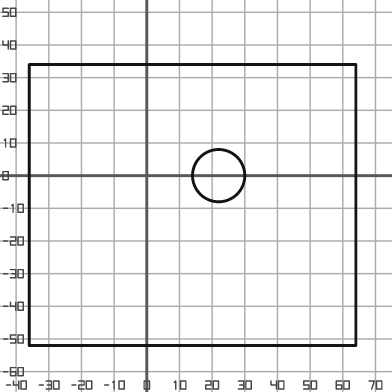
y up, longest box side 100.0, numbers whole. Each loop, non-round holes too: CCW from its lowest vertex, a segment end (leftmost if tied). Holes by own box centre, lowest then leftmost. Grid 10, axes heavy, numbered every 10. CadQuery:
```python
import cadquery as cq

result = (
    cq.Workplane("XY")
    .moveTo(-36.0, -52.0)
    .lineTo(64.0, -52.0)
    .lineTo(64.0, 34.0)
    .lineTo(-36.0, 34.0)
    .close()
    .moveTo(22.0, 0.0)
    .circle(8.0)
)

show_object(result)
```